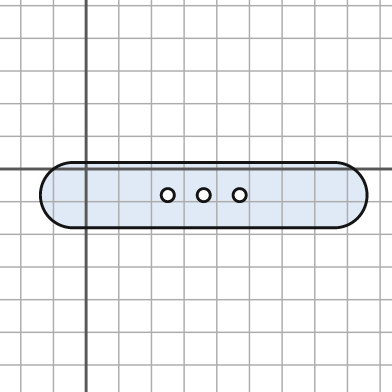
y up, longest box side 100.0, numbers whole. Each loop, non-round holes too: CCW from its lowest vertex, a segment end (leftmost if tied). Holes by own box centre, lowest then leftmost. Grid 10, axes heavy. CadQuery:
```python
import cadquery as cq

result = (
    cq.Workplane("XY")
    .moveTo(-4.0, -18.0)
    .lineTo(76.0, -18.0)
    .threePointArc((86.0, -8.0), (76.0, 2.0))
    .lineTo(-4.0, 2.0)
    .threePointArc((-14.0, -8.0), (-4.0, -18.0))
    .close()
    .moveTo(25.0, -8.0)
    .circle(2.0)
    .moveTo(36.0, -8.0)
    .circle(2.0)
    .moveTo(47.0, -8.0)
    .circle(2.0)
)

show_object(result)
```